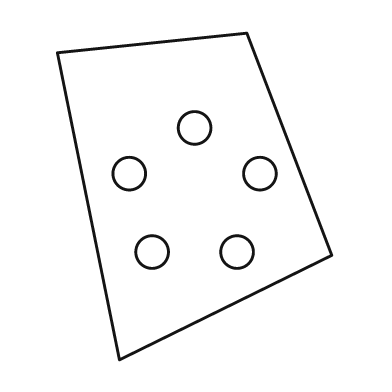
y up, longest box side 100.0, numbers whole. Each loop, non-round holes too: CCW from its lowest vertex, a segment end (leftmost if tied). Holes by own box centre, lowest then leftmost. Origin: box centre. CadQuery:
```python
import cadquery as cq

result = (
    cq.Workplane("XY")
    .moveTo(-23.0, -50.0)
    .lineTo(42.0, -18.0)
    .lineTo(16.0, 50.0)
    .lineTo(-42.0, 44.0)
    .close()
    .moveTo(-13.0, -17.0)
    .circle(5.0)
    .moveTo(13.0, -17.0)
    .circle(5.0)
    .moveTo(-20.0, 7.0)
    .circle(5.0)
    .moveTo(20.0, 7.0)
    .circle(5.0)
    .moveTo(0.0, 21.0)
    .circle(5.0)
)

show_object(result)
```